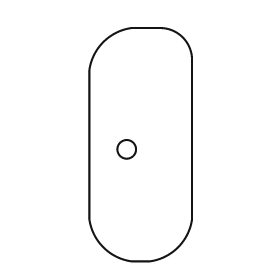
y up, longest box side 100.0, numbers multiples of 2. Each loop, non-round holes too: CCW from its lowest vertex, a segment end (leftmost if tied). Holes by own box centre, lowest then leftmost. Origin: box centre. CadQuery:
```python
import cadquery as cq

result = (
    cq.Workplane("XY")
    .moveTo(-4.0, -50.0)
    .lineTo(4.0, -50.0)
    .threePointArc((16.0, -44.0), (22.0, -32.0))
    .lineTo(22.0, 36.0)
    .threePointArc((18.0, 46.0), (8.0, 50.0))
    .lineTo(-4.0, 50.0)
    .threePointArc((-16.0, 44.0), (-22.0, 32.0))
    .lineTo(-22.0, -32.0)
    .threePointArc((-16.0, -44.0), (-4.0, -50.0))
    .close()
    .moveTo(-6.0, -2.0)
    .circle(4.0)
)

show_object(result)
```